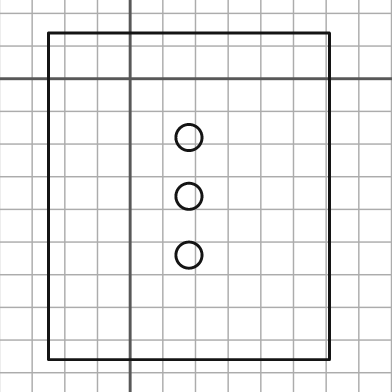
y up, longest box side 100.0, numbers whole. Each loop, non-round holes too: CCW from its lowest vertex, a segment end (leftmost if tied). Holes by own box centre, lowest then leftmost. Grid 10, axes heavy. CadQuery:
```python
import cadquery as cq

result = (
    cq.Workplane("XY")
    .moveTo(-25.0, -86.0)
    .lineTo(61.0, -86.0)
    .lineTo(61.0, 14.0)
    .lineTo(-25.0, 14.0)
    .close()
    .moveTo(18.0, -54.0)
    .circle(4.0)
    .moveTo(18.0, -36.0)
    .circle(4.0)
    .moveTo(18.0, -18.0)
    .circle(4.0)
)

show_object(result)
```